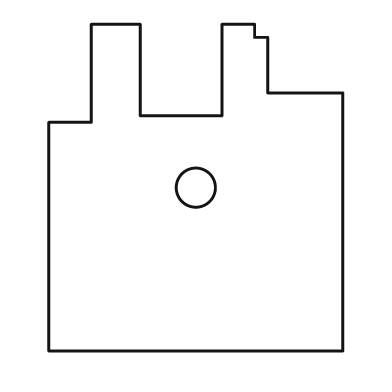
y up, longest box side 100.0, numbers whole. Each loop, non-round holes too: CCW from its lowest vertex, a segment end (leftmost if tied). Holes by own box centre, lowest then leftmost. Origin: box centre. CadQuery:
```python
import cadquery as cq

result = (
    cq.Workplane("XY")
    .moveTo(-45.0, -50.0)
    .lineTo(45.0, -50.0)
    .lineTo(45.0, 29.0)
    .lineTo(22.0, 29.0)
    .lineTo(22.0, 46.0)
    .lineTo(18.0, 46.0)
    .lineTo(18.0, 50.0)
    .lineTo(8.0, 50.0)
    .lineTo(8.0, 22.0)
    .lineTo(-17.0, 22.0)
    .lineTo(-17.0, 50.0)
    .lineTo(-32.0, 50.0)
    .lineTo(-32.0, 20.0)
    .lineTo(-45.0, 20.0)
    .close()
    .moveTo(0.0, 0.0)
    .circle(6.0)
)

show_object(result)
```